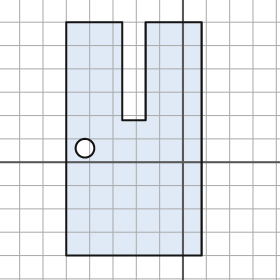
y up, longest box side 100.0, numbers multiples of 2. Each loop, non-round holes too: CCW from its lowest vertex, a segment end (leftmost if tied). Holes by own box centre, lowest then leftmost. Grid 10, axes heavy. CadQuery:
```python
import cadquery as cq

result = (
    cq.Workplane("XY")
    .moveTo(-50.0, -40.0)
    .lineTo(8.0, -40.0)
    .lineTo(8.0, 60.0)
    .lineTo(-16.0, 60.0)
    .lineTo(-16.0, 18.0)
    .lineTo(-26.0, 18.0)
    .lineTo(-26.0, 60.0)
    .lineTo(-50.0, 60.0)
    .close()
    .moveTo(-42.0, 6.0)
    .circle(4.0)
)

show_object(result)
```